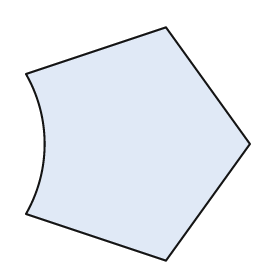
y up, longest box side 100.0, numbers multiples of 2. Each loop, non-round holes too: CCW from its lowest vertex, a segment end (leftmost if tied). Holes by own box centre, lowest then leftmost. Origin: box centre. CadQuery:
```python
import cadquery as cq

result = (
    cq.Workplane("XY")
    .moveTo(12.0, -50.0)
    .lineTo(48.0, 0.0)
    .lineTo(12.0, 50.0)
    .lineTo(-48.0, 30.0)
    .threePointArc((-40.0, 0.0), (-48.0, -30.0))
    .close()
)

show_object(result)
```